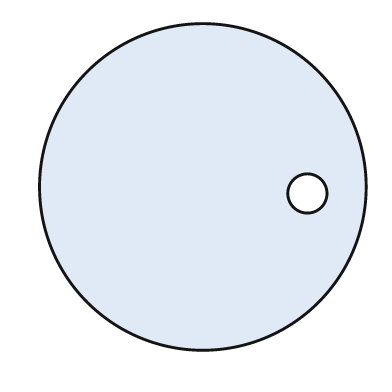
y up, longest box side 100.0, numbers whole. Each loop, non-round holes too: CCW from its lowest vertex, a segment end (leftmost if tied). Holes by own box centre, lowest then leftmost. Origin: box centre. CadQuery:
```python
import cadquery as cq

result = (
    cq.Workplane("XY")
    .moveTo(0.0, 0.0)
    .circle(50.0)
    .moveTo(32.0, -2.0)
    .circle(6.0)
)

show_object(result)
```